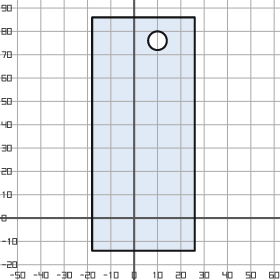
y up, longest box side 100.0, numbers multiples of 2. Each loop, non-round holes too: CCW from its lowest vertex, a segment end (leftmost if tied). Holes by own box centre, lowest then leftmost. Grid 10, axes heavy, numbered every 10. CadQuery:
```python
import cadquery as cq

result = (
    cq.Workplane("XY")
    .moveTo(-18.0, -14.0)
    .lineTo(26.0, -14.0)
    .lineTo(26.0, 86.0)
    .lineTo(-18.0, 86.0)
    .close()
    .moveTo(10.0, 76.0)
    .circle(4.0)
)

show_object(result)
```